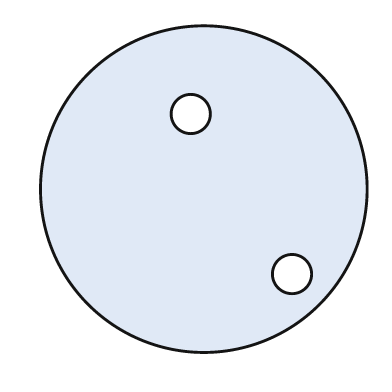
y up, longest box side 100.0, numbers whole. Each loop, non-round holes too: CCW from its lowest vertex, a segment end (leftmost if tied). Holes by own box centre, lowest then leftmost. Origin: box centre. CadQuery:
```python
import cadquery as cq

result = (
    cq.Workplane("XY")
    .moveTo(0.0, 0.0)
    .circle(50.0)
    .moveTo(27.0, -26.0)
    .circle(6.0)
    .moveTo(-4.0, 23.0)
    .circle(6.0)
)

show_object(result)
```